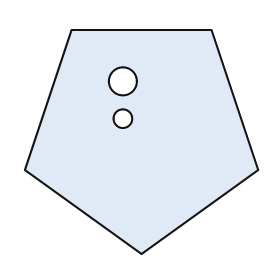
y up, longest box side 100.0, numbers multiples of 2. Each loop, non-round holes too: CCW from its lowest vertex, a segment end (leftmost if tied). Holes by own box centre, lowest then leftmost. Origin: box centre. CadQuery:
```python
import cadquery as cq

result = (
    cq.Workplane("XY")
    .moveTo(0.0, -48.0)
    .lineTo(50.0, -12.0)
    .lineTo(30.0, 48.0)
    .lineTo(-30.0, 48.0)
    .lineTo(-50.0, -12.0)
    .close()
    .moveTo(-8.0, 10.0)
    .circle(4.0)
    .moveTo(-8.0, 26.0)
    .circle(6.0)
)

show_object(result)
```